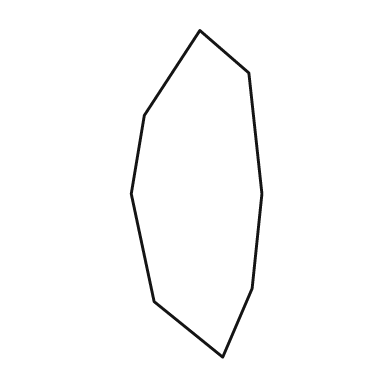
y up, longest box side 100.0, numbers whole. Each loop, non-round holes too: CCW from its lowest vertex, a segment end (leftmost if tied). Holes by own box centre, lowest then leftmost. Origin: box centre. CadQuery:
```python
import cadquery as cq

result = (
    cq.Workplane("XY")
    .moveTo(8.0, -50.0)
    .lineTo(17.0, -29.0)
    .lineTo(20.0, 0.0)
    .lineTo(16.0, 37.0)
    .lineTo(1.0, 50.0)
    .lineTo(-16.0, 24.0)
    .lineTo(-20.0, 0.0)
    .lineTo(-13.0, -33.0)
    .close()
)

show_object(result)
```